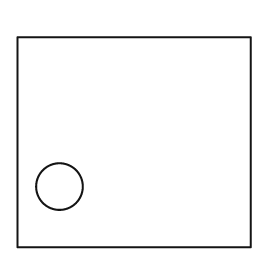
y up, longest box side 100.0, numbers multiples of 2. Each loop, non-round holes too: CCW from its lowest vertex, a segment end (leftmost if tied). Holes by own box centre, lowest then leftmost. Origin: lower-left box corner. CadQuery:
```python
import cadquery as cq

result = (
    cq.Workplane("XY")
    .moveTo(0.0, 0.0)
    .lineTo(100.0, 0.0)
    .lineTo(100.0, 90.0)
    .lineTo(0.0, 90.0)
    .close()
    .moveTo(18.0, 26.0)
    .circle(10.0)
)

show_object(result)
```